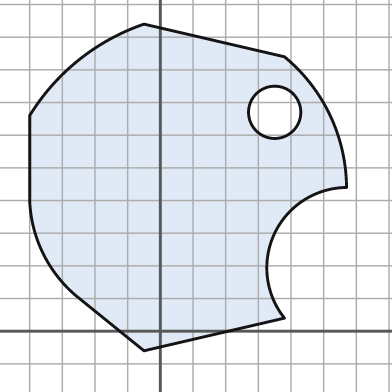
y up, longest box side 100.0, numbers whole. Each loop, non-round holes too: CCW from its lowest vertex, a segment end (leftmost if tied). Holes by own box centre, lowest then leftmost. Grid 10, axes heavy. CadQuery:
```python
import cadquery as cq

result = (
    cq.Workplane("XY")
    .moveTo(-5.0, -6.0)
    .lineTo(38.0, 4.0)
    .threePointArc((35.0, 30.0), (57.0, 44.0))
    .threePointArc((52.0, 66.0), (38.0, 84.0))
    .lineTo(-5.0, 94.0)
    .threePointArc((-25.0, 83.0), (-40.0, 66.0))
    .lineTo(-40.0, 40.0)
    .threePointArc((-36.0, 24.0), (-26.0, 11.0))
    .close()
    .moveTo(35.0, 67.0)
    .circle(8.0)
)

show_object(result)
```